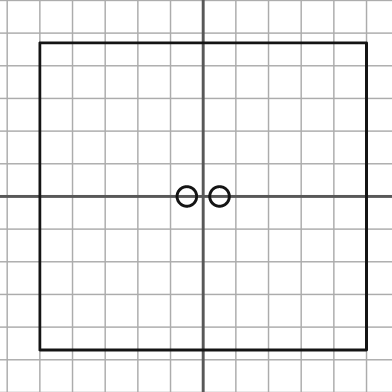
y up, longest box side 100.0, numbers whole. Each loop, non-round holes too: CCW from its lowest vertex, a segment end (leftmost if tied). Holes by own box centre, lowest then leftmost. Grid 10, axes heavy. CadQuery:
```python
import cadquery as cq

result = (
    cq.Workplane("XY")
    .moveTo(-50.0, -47.0)
    .lineTo(50.0, -47.0)
    .lineTo(50.0, 47.0)
    .lineTo(-50.0, 47.0)
    .close()
    .moveTo(-5.0, 0.0)
    .circle(3.0)
    .moveTo(5.0, 0.0)
    .circle(3.0)
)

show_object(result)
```